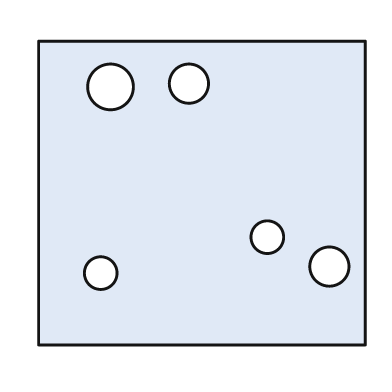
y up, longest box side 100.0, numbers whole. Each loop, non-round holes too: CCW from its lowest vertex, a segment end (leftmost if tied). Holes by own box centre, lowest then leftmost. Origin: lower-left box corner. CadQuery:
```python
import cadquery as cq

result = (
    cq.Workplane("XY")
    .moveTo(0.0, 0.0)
    .lineTo(100.0, 0.0)
    .lineTo(100.0, 93.0)
    .lineTo(0.0, 93.0)
    .close()
    .moveTo(19.0, 22.0)
    .circle(5.0)
    .moveTo(89.0, 24.0)
    .circle(6.0)
    .moveTo(70.0, 33.0)
    .circle(5.0)
    .moveTo(22.0, 79.0)
    .circle(7.0)
    .moveTo(46.0, 80.0)
    .circle(6.0)
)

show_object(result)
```